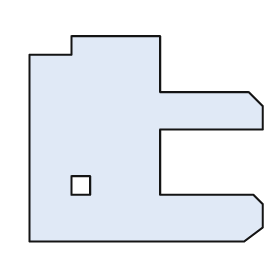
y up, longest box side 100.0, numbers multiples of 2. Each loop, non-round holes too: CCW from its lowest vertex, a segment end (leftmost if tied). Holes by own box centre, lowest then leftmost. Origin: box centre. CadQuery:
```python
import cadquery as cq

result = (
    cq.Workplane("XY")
    .moveTo(-50.0, -44.0)
    .lineTo(42.0, -44.0)
    .lineTo(50.0, -38.0)
    .lineTo(50.0, -28.0)
    .lineTo(46.0, -24.0)
    .lineTo(6.0, -24.0)
    .lineTo(6.0, 4.0)
    .lineTo(50.0, 4.0)
    .lineTo(50.0, 14.0)
    .lineTo(44.0, 20.0)
    .lineTo(6.0, 20.0)
    .lineTo(6.0, 44.0)
    .lineTo(-32.0, 44.0)
    .lineTo(-32.0, 36.0)
    .lineTo(-50.0, 36.0)
    .close()
    .moveTo(-32.0, -24.0)
    .lineTo(-24.0, -24.0)
    .lineTo(-24.0, -16.0)
    .lineTo(-32.0, -16.0)
    .close()
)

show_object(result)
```